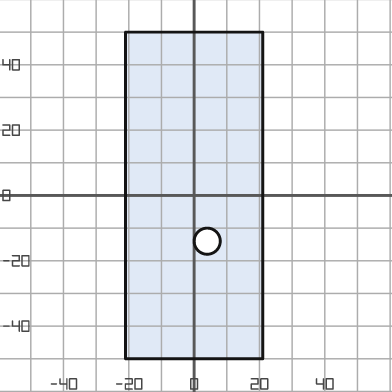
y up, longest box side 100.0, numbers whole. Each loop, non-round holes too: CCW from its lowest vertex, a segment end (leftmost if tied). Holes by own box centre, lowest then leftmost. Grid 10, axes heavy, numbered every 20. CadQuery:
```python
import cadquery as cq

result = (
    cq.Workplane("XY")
    .moveTo(-21.0, -50.0)
    .lineTo(21.0, -50.0)
    .lineTo(21.0, 50.0)
    .lineTo(-21.0, 50.0)
    .close()
    .moveTo(4.0, -14.0)
    .circle(4.0)
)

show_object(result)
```